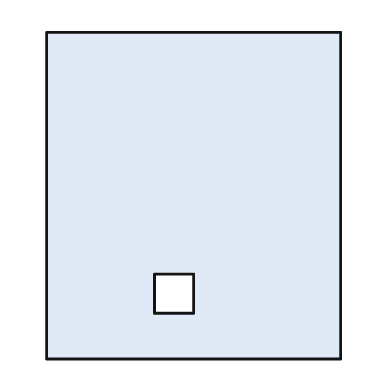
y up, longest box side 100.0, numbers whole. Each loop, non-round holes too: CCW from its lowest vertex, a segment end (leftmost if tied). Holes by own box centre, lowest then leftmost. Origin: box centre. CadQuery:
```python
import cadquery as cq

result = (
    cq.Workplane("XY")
    .moveTo(-45.0, -50.0)
    .lineTo(45.0, -50.0)
    .lineTo(45.0, 50.0)
    .lineTo(-45.0, 50.0)
    .close()
    .moveTo(-12.0, -36.0)
    .lineTo(0.0, -36.0)
    .lineTo(0.0, -24.0)
    .lineTo(-12.0, -24.0)
    .close()
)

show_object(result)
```